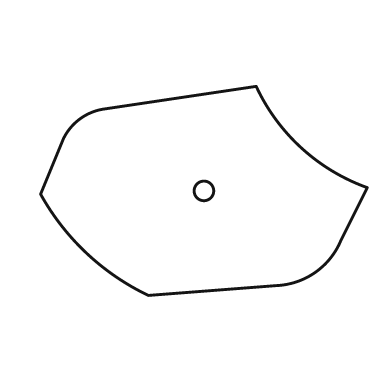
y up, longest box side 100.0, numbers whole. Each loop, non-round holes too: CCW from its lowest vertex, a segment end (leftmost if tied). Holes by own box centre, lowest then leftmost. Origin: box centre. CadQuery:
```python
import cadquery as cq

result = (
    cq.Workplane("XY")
    .moveTo(-17.0, -32.0)
    .lineTo(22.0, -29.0)
    .threePointArc((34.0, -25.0), (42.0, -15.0))
    .lineTo(50.0, 1.0)
    .threePointArc((30.0, 13.0), (16.0, 32.0))
    .lineTo(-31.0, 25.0)
    .threePointArc((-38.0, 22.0), (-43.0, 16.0))
    .lineTo(-50.0, -1.0)
    .threePointArc((-36.0, -19.0), (-17.0, -32.0))
    .close()
    .moveTo(0.0, 0.0)
    .circle(3.0)
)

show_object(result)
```